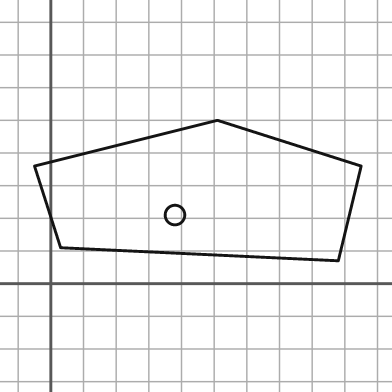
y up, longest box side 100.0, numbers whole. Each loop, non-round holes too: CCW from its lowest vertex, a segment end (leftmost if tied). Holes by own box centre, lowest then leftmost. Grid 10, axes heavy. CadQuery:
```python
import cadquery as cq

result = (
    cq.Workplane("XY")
    .moveTo(88.0, 7.0)
    .lineTo(95.0, 36.0)
    .lineTo(51.0, 50.0)
    .lineTo(-5.0, 36.0)
    .lineTo(3.0, 11.0)
    .close()
    .moveTo(38.0, 21.0)
    .circle(3.0)
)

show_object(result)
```